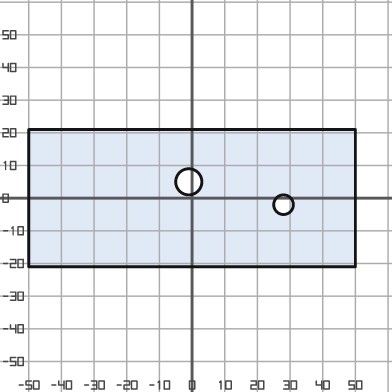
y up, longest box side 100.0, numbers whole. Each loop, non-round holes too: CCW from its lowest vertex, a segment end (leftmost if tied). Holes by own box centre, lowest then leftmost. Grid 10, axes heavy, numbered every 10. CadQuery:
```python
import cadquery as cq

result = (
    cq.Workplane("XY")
    .moveTo(-50.0, -21.0)
    .lineTo(50.0, -21.0)
    .lineTo(50.0, 21.0)
    .lineTo(-50.0, 21.0)
    .close()
    .moveTo(28.0, -2.0)
    .circle(3.0)
    .moveTo(-1.0, 5.0)
    .circle(4.0)
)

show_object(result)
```